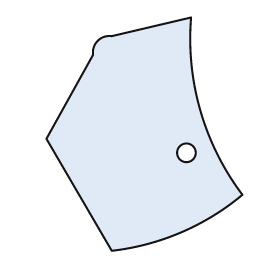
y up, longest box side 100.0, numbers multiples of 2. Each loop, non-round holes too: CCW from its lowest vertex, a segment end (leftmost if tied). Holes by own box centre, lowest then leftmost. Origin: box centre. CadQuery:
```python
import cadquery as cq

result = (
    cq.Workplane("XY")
    .moveTo(-14.0, -50.0)
    .threePointArc((16.0, -42.0), (42.0, -26.0))
    .threePointArc((24.0, 10.0), (20.0, 50.0))
    .lineTo(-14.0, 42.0)
    .threePointArc((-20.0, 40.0), (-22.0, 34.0))
    .lineTo(-42.0, -2.0)
    .close()
    .moveTo(18.0, -8.0)
    .circle(4.0)
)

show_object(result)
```